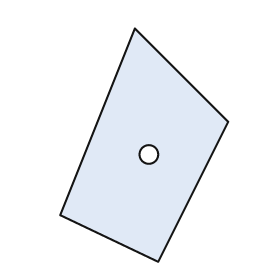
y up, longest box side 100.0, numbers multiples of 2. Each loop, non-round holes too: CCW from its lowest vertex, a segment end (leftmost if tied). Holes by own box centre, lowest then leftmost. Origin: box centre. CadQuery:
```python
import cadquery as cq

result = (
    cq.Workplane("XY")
    .moveTo(6.0, -50.0)
    .lineTo(36.0, 10.0)
    .lineTo(-4.0, 50.0)
    .lineTo(-36.0, -30.0)
    .close()
    .moveTo(2.0, -4.0)
    .circle(4.0)
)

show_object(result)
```